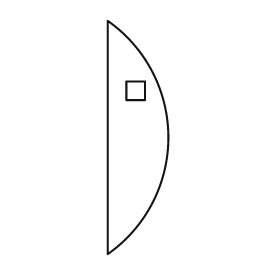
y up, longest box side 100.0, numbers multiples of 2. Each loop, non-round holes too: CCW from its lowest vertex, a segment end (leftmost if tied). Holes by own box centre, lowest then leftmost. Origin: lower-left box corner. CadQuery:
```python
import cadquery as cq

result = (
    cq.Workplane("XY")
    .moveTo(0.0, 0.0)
    .threePointArc((26.0, 50.0), (0.0, 100.0))
    .close()
    .moveTo(8.0, 66.0)
    .lineTo(16.0, 66.0)
    .lineTo(16.0, 74.0)
    .lineTo(8.0, 74.0)
    .close()
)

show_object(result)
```